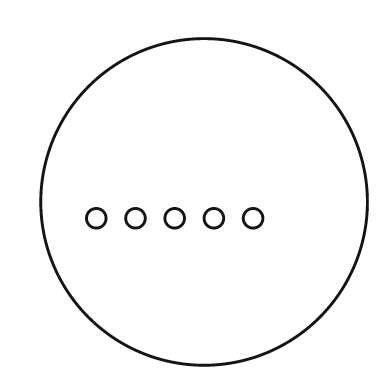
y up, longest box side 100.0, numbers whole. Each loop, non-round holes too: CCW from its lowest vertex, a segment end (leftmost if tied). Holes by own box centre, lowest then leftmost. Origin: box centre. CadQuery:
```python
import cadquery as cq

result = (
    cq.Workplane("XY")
    .moveTo(0.0, 0.0)
    .circle(50.0)
    .moveTo(-33.0, -5.0)
    .circle(3.0)
    .moveTo(-21.0, -5.0)
    .circle(3.0)
    .moveTo(-9.0, -5.0)
    .circle(3.0)
    .moveTo(3.0, -5.0)
    .circle(3.0)
    .moveTo(15.0, -5.0)
    .circle(3.0)
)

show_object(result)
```